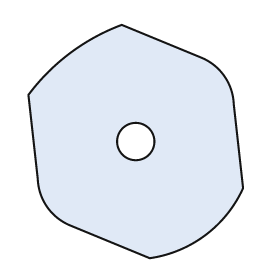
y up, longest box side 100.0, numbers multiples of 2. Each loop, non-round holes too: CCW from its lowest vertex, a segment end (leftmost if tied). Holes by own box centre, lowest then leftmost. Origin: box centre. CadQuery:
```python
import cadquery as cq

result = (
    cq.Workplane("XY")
    .moveTo(6.0, -50.0)
    .threePointArc((30.0, -40.0), (46.0, -20.0))
    .lineTo(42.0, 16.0)
    .threePointArc((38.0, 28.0), (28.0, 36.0))
    .lineTo(-6.0, 50.0)
    .threePointArc((-28.0, 38.0), (-46.0, 20.0))
    .lineTo(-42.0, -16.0)
    .threePointArc((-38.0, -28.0), (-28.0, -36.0))
    .close()
    .moveTo(0.0, 0.0)
    .circle(8.0)
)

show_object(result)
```